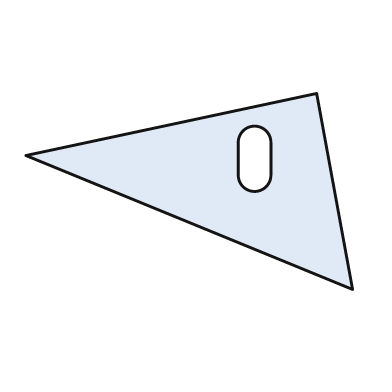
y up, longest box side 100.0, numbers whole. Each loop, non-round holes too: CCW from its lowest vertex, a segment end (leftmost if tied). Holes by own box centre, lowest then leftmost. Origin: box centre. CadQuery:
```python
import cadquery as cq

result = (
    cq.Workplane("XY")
    .moveTo(50.0, -30.0)
    .lineTo(39.0, 30.0)
    .lineTo(-50.0, 11.0)
    .close()
    .moveTo(15.0, 5.0)
    .threePointArc((20.0, 0.0), (25.0, 5.0))
    .lineTo(25.0, 15.0)
    .threePointArc((20.0, 20.0), (15.0, 15.0))
    .close()
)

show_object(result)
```